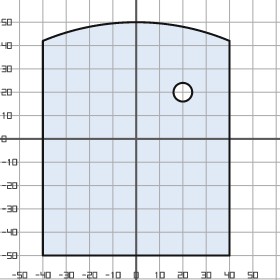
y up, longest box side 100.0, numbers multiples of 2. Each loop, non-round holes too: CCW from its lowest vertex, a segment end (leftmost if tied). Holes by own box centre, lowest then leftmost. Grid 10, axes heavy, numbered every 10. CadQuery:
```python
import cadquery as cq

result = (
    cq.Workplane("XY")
    .moveTo(-40.0, -50.0)
    .lineTo(40.0, -50.0)
    .lineTo(40.0, 42.0)
    .threePointArc((0.0, 50.0), (-40.0, 42.0))
    .close()
    .moveTo(20.0, 20.0)
    .circle(4.0)
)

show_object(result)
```